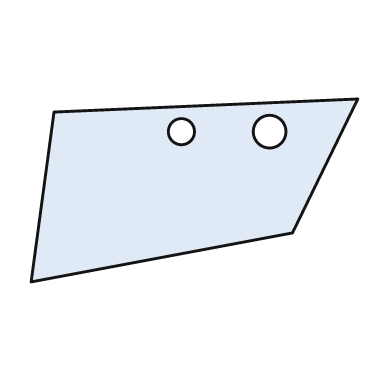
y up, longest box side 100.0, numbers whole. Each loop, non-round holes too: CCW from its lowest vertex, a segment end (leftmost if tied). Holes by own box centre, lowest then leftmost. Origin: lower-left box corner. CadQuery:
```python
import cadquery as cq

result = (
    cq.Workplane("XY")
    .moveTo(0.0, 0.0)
    .lineTo(80.0, 15.0)
    .lineTo(100.0, 56.0)
    .lineTo(7.0, 52.0)
    .close()
    .moveTo(46.0, 46.0)
    .circle(4.0)
    .moveTo(73.0, 46.0)
    .circle(5.0)
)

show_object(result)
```